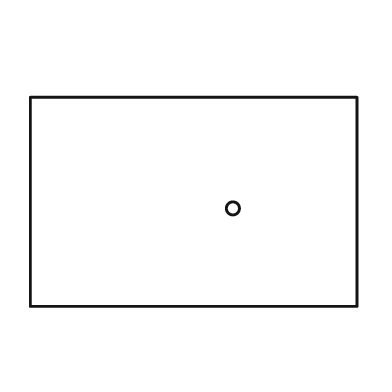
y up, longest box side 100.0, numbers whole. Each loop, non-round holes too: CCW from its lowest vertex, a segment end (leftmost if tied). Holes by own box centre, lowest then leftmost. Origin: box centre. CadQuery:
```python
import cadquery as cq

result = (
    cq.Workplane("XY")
    .moveTo(-50.0, -32.0)
    .lineTo(50.0, -32.0)
    .lineTo(50.0, 32.0)
    .lineTo(-50.0, 32.0)
    .close()
    .moveTo(12.0, -2.0)
    .circle(2.0)
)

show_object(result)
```